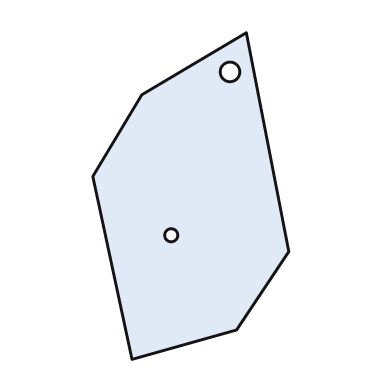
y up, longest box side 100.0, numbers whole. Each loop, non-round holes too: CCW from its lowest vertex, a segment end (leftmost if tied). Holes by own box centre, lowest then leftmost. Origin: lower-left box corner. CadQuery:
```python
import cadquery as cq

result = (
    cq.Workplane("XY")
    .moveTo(12.0, 0.0)
    .lineTo(44.0, 9.0)
    .lineTo(60.0, 33.0)
    .lineTo(47.0, 100.0)
    .lineTo(15.0, 81.0)
    .lineTo(0.0, 56.0)
    .close()
    .moveTo(24.0, 38.0)
    .circle(2.0)
    .moveTo(42.0, 88.0)
    .circle(3.0)
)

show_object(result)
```